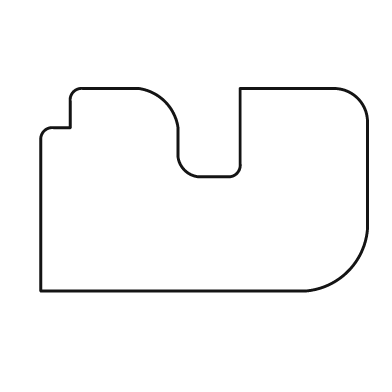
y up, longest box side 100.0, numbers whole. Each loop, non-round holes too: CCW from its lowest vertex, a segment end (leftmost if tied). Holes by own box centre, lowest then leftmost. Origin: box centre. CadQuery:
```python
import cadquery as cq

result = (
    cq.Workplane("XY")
    .moveTo(-50.0, -31.0)
    .lineTo(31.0, -31.0)
    .threePointArc((44.0, -25.0), (50.0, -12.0))
    .lineTo(50.0, 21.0)
    .threePointArc((47.0, 28.0), (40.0, 31.0))
    .lineTo(11.0, 31.0)
    .lineTo(11.0, 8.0)
    .threePointArc((10.0, 5.0), (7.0, 4.0))
    .lineTo(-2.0, 4.0)
    .threePointArc((-6.0, 6.0), (-8.0, 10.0))
    .lineTo(-8.0, 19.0)
    .threePointArc((-12.0, 27.0), (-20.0, 31.0))
    .lineTo(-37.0, 31.0)
    .threePointArc((-40.0, 30.0), (-41.0, 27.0))
    .lineTo(-41.0, 19.0)
    .lineTo(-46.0, 19.0)
    .threePointArc((-49.0, 18.0), (-50.0, 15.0))
    .close()
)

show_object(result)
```